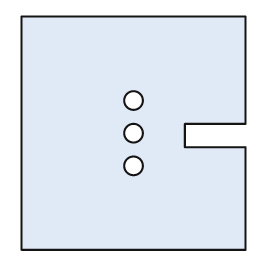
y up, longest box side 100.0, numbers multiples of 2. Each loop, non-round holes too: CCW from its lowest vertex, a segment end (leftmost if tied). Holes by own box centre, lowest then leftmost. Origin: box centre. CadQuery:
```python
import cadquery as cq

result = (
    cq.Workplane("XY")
    .moveTo(-48.0, -50.0)
    .lineTo(48.0, -50.0)
    .lineTo(48.0, -6.0)
    .lineTo(22.0, -6.0)
    .lineTo(22.0, 4.0)
    .lineTo(48.0, 4.0)
    .lineTo(48.0, 50.0)
    .lineTo(-48.0, 50.0)
    .close()
    .moveTo(0.0, -14.0)
    .circle(4.0)
    .moveTo(0.0, 0.0)
    .circle(4.0)
    .moveTo(0.0, 14.0)
    .circle(4.0)
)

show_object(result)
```